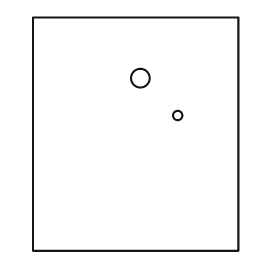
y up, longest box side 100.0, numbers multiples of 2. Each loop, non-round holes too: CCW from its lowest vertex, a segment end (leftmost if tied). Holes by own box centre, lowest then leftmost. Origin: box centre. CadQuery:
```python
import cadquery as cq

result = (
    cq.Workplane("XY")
    .moveTo(-44.0, -50.0)
    .lineTo(44.0, -50.0)
    .lineTo(44.0, 50.0)
    .lineTo(-44.0, 50.0)
    .close()
    .moveTo(18.0, 8.0)
    .circle(2.0)
    .moveTo(2.0, 24.0)
    .circle(4.0)
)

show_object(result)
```